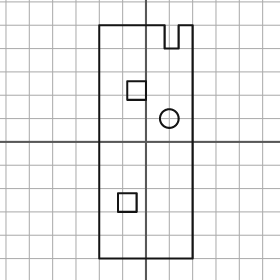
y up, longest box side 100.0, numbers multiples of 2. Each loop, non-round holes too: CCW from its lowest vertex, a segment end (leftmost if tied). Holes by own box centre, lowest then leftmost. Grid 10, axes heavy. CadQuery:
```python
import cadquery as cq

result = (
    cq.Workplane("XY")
    .moveTo(-20.0, -50.0)
    .lineTo(20.0, -50.0)
    .lineTo(20.0, 50.0)
    .lineTo(14.0, 50.0)
    .lineTo(14.0, 40.0)
    .lineTo(8.0, 40.0)
    .lineTo(8.0, 50.0)
    .lineTo(-20.0, 50.0)
    .close()
    .moveTo(-12.0, -30.0)
    .lineTo(-4.0, -30.0)
    .lineTo(-4.0, -22.0)
    .lineTo(-12.0, -22.0)
    .close()
    .moveTo(10.0, 10.0)
    .circle(4.0)
    .moveTo(-8.0, 18.0)
    .lineTo(0.0, 18.0)
    .lineTo(0.0, 26.0)
    .lineTo(-8.0, 26.0)
    .close()
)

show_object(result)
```